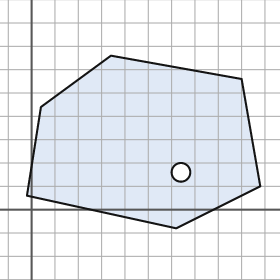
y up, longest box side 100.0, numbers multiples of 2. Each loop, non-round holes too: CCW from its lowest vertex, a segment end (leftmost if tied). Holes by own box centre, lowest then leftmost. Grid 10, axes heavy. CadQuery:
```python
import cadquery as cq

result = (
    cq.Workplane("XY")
    .moveTo(62.0, -8.0)
    .lineTo(98.0, 10.0)
    .lineTo(90.0, 56.0)
    .lineTo(34.0, 66.0)
    .lineTo(4.0, 44.0)
    .lineTo(-2.0, 6.0)
    .close()
    .moveTo(64.0, 16.0)
    .circle(4.0)
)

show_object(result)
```